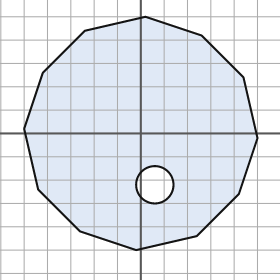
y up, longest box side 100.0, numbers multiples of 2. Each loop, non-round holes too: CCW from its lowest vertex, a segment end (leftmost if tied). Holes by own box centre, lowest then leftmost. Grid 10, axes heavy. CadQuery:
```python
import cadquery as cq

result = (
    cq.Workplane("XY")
    .moveTo(-2.0, -50.0)
    .lineTo(24.0, -44.0)
    .lineTo(42.0, -26.0)
    .lineTo(50.0, -2.0)
    .lineTo(44.0, 24.0)
    .lineTo(26.0, 42.0)
    .lineTo(2.0, 50.0)
    .lineTo(-24.0, 44.0)
    .lineTo(-42.0, 26.0)
    .lineTo(-50.0, 2.0)
    .lineTo(-44.0, -24.0)
    .lineTo(-26.0, -42.0)
    .close()
    .moveTo(6.0, -22.0)
    .circle(8.0)
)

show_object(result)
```